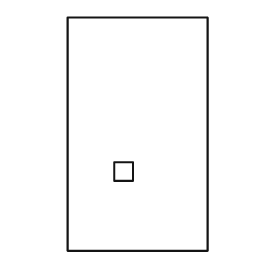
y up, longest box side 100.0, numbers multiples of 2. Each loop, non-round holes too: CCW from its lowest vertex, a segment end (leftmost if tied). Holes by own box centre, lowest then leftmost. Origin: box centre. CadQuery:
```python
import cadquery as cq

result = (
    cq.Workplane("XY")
    .moveTo(-30.0, -50.0)
    .lineTo(30.0, -50.0)
    .lineTo(30.0, 50.0)
    .lineTo(-30.0, 50.0)
    .close()
    .moveTo(-10.0, -20.0)
    .lineTo(-2.0, -20.0)
    .lineTo(-2.0, -12.0)
    .lineTo(-10.0, -12.0)
    .close()
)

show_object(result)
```